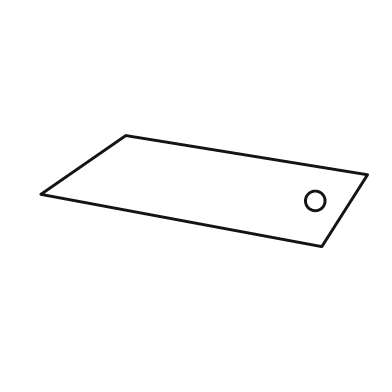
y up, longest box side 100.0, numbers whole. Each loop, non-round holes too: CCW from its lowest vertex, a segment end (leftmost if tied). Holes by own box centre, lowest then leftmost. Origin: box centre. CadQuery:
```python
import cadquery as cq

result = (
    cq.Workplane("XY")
    .moveTo(36.0, -17.0)
    .lineTo(50.0, 5.0)
    .lineTo(-24.0, 17.0)
    .lineTo(-50.0, -1.0)
    .close()
    .moveTo(34.0, -3.0)
    .circle(3.0)
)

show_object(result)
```